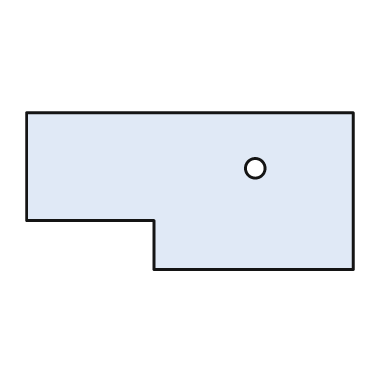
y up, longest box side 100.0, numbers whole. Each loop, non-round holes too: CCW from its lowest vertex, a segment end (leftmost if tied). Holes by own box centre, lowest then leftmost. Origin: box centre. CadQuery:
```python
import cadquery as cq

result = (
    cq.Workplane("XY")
    .moveTo(-11.0, -24.0)
    .lineTo(50.0, -24.0)
    .lineTo(50.0, 24.0)
    .lineTo(-50.0, 24.0)
    .lineTo(-50.0, -9.0)
    .lineTo(-11.0, -9.0)
    .close()
    .moveTo(20.0, 7.0)
    .circle(3.0)
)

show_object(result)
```